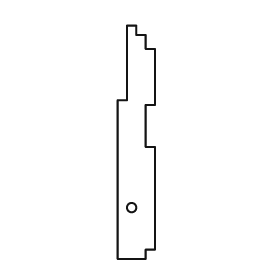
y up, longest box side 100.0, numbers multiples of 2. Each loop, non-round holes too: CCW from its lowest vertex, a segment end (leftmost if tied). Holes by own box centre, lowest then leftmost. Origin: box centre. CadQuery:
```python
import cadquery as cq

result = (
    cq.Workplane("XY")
    .moveTo(-8.0, -50.0)
    .lineTo(4.0, -50.0)
    .lineTo(4.0, -46.0)
    .lineTo(8.0, -46.0)
    .lineTo(8.0, -2.0)
    .lineTo(4.0, -2.0)
    .lineTo(4.0, 16.0)
    .lineTo(8.0, 16.0)
    .lineTo(8.0, 40.0)
    .lineTo(4.0, 40.0)
    .lineTo(4.0, 46.0)
    .lineTo(0.0, 46.0)
    .lineTo(0.0, 50.0)
    .lineTo(-4.0, 50.0)
    .lineTo(-4.0, 18.0)
    .lineTo(-8.0, 18.0)
    .close()
    .moveTo(-2.0, -28.0)
    .circle(2.0)
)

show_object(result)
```